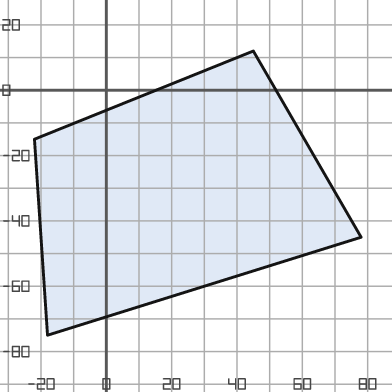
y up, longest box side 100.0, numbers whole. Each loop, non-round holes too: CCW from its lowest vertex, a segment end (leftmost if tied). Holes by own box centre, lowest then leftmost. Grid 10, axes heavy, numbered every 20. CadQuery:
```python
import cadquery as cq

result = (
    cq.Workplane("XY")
    .moveTo(-18.0, -75.0)
    .lineTo(78.0, -45.0)
    .lineTo(45.0, 12.0)
    .lineTo(-22.0, -15.0)
    .close()
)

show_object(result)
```